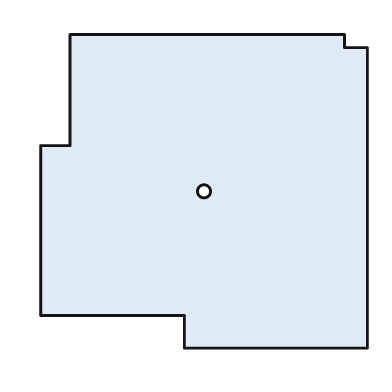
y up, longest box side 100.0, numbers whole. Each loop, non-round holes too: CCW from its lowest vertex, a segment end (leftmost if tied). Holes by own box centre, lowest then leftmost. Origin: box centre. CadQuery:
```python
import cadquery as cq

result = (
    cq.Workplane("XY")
    .moveTo(-6.0, -48.0)
    .lineTo(50.0, -48.0)
    .lineTo(50.0, 44.0)
    .lineTo(43.0, 44.0)
    .lineTo(43.0, 48.0)
    .lineTo(-41.0, 48.0)
    .lineTo(-41.0, 14.0)
    .lineTo(-50.0, 14.0)
    .lineTo(-50.0, -38.0)
    .lineTo(-6.0, -38.0)
    .close()
    .moveTo(0.0, 0.0)
    .circle(2.0)
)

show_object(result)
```